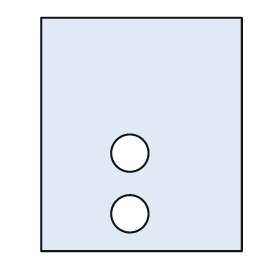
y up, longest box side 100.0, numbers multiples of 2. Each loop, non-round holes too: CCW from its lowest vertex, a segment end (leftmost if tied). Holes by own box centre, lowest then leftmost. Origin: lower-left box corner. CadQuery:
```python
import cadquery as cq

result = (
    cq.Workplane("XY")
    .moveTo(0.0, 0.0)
    .lineTo(86.0, 0.0)
    .lineTo(86.0, 100.0)
    .lineTo(0.0, 100.0)
    .close()
    .moveTo(38.0, 16.0)
    .circle(8.0)
    .moveTo(38.0, 42.0)
    .circle(8.0)
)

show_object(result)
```